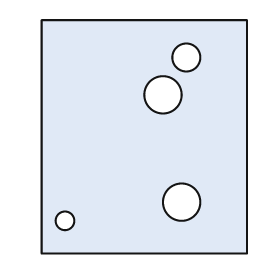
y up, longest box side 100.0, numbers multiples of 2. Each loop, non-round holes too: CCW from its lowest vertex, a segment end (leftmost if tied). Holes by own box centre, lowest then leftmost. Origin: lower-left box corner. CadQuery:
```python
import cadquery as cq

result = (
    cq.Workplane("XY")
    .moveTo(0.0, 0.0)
    .lineTo(88.0, 0.0)
    .lineTo(88.0, 100.0)
    .lineTo(0.0, 100.0)
    .close()
    .moveTo(10.0, 14.0)
    .circle(4.0)
    .moveTo(60.0, 22.0)
    .circle(8.0)
    .moveTo(52.0, 68.0)
    .circle(8.0)
    .moveTo(62.0, 84.0)
    .circle(6.0)
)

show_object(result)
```